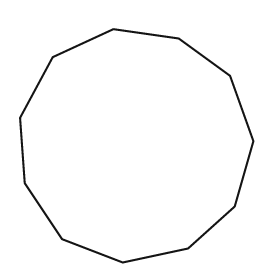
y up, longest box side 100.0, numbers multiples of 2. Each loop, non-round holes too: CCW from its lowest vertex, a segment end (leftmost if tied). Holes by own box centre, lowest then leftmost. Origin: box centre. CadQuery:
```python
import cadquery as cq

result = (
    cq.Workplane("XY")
    .moveTo(-6.0, -50.0)
    .lineTo(22.0, -44.0)
    .lineTo(42.0, -26.0)
    .lineTo(50.0, 2.0)
    .lineTo(40.0, 30.0)
    .lineTo(18.0, 46.0)
    .lineTo(-10.0, 50.0)
    .lineTo(-36.0, 38.0)
    .lineTo(-50.0, 12.0)
    .lineTo(-48.0, -16.0)
    .lineTo(-32.0, -40.0)
    .close()
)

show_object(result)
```